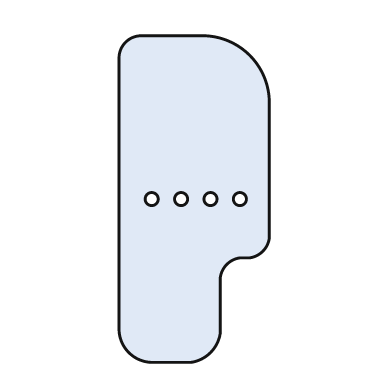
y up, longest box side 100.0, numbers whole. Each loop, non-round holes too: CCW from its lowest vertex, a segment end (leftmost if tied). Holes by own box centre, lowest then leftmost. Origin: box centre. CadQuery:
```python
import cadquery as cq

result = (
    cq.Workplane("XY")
    .moveTo(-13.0, -50.0)
    .lineTo(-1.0, -50.0)
    .threePointArc((5.0, -47.0), (8.0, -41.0))
    .lineTo(8.0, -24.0)
    .threePointArc((10.0, -20.0), (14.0, -18.0))
    .lineTo(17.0, -18.0)
    .threePointArc((21.0, -16.0), (23.0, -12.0))
    .lineTo(23.0, 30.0)
    .threePointArc((17.0, 44.0), (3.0, 50.0))
    .lineTo(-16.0, 50.0)
    .threePointArc((-21.0, 48.0), (-23.0, 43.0))
    .lineTo(-23.0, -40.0)
    .threePointArc((-20.0, -47.0), (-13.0, -50.0))
    .close()
    .moveTo(-13.0, 0.0)
    .circle(2.0)
    .moveTo(-4.0, 0.0)
    .circle(2.0)
    .moveTo(5.0, 0.0)
    .circle(2.0)
    .moveTo(14.0, 0.0)
    .circle(2.0)
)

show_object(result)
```